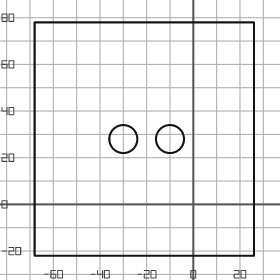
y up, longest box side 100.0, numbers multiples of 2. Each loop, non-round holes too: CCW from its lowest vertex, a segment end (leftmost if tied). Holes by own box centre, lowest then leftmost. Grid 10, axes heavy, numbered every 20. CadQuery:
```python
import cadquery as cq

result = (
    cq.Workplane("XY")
    .moveTo(-68.0, -22.0)
    .lineTo(26.0, -22.0)
    .lineTo(26.0, 78.0)
    .lineTo(-68.0, 78.0)
    .close()
    .moveTo(-30.0, 28.0)
    .circle(6.0)
    .moveTo(-10.0, 28.0)
    .circle(6.0)
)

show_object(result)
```